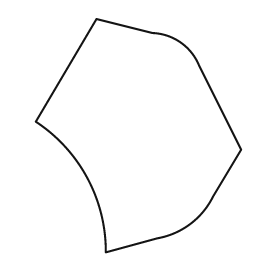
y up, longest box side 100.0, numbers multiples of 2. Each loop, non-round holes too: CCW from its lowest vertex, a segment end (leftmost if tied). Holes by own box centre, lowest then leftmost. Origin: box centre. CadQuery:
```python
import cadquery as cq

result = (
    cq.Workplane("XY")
    .moveTo(-14.0, -50.0)
    .lineTo(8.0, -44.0)
    .threePointArc((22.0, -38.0), (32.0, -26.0))
    .lineTo(44.0, -6.0)
    .lineTo(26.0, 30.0)
    .threePointArc((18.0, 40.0), (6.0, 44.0))
    .lineTo(-18.0, 50.0)
    .lineTo(-44.0, 6.0)
    .threePointArc((-22.0, -18.0), (-14.0, -50.0))
    .close()
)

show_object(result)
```